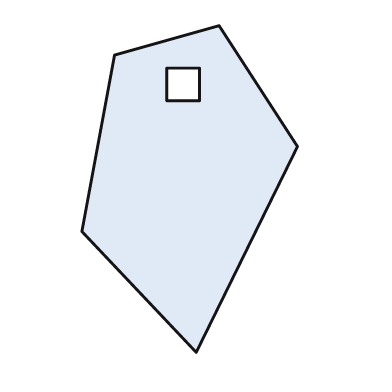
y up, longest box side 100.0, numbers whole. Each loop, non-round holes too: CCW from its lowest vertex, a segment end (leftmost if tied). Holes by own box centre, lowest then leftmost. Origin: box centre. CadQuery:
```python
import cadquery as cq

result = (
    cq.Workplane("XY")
    .moveTo(2.0, -50.0)
    .lineTo(33.0, 13.0)
    .lineTo(9.0, 50.0)
    .lineTo(-23.0, 41.0)
    .lineTo(-33.0, -13.0)
    .close()
    .moveTo(-7.0, 27.0)
    .lineTo(3.0, 27.0)
    .lineTo(3.0, 37.0)
    .lineTo(-7.0, 37.0)
    .close()
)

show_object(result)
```